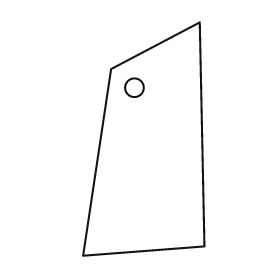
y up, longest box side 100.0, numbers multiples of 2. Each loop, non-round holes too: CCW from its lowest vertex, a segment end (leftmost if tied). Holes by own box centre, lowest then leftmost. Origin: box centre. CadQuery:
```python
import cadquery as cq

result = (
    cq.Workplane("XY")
    .moveTo(-26.0, -50.0)
    .lineTo(26.0, -46.0)
    .lineTo(24.0, 50.0)
    .lineTo(-14.0, 30.0)
    .close()
    .moveTo(-4.0, 22.0)
    .circle(4.0)
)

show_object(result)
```